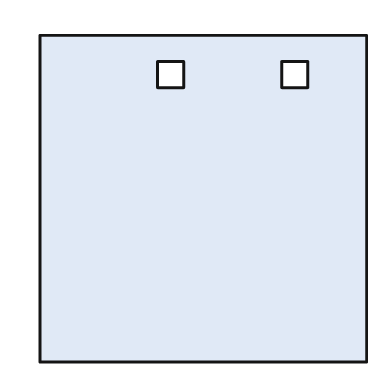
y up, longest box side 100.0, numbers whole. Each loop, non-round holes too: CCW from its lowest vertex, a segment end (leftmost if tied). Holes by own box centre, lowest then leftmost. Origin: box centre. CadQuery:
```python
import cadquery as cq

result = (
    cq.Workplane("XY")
    .moveTo(-50.0, -50.0)
    .lineTo(50.0, -50.0)
    .lineTo(50.0, 50.0)
    .lineTo(-50.0, 50.0)
    .close()
    .moveTo(-14.0, 34.0)
    .lineTo(-6.0, 34.0)
    .lineTo(-6.0, 42.0)
    .lineTo(-14.0, 42.0)
    .close()
    .moveTo(24.0, 34.0)
    .lineTo(32.0, 34.0)
    .lineTo(32.0, 42.0)
    .lineTo(24.0, 42.0)
    .close()
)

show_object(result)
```